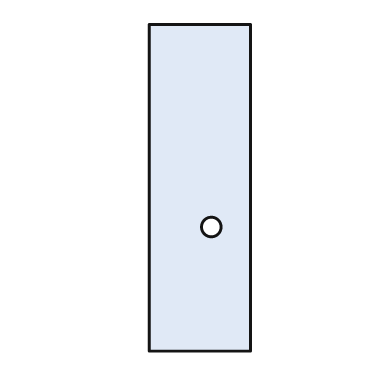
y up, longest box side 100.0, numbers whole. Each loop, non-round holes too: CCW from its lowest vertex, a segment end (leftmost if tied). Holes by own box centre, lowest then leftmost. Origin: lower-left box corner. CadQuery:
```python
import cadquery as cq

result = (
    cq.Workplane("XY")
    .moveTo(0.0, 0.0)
    .lineTo(31.0, 0.0)
    .lineTo(31.0, 100.0)
    .lineTo(0.0, 100.0)
    .close()
    .moveTo(19.0, 38.0)
    .circle(3.0)
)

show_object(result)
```